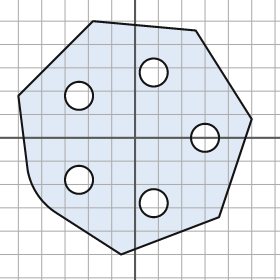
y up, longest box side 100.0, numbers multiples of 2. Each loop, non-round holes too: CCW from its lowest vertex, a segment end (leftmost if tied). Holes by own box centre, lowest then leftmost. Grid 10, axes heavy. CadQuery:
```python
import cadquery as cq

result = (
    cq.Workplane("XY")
    .moveTo(-6.0, -50.0)
    .lineTo(36.0, -34.0)
    .lineTo(50.0, 8.0)
    .lineTo(26.0, 46.0)
    .lineTo(-18.0, 50.0)
    .lineTo(-50.0, 18.0)
    .lineTo(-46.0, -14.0)
    .threePointArc((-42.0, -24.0), (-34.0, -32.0))
    .close()
    .moveTo(8.0, -28.0)
    .circle(6.0)
    .moveTo(-24.0, -18.0)
    .circle(6.0)
    .moveTo(30.0, 0.0)
    .circle(6.0)
    .moveTo(-24.0, 18.0)
    .circle(6.0)
    .moveTo(8.0, 28.0)
    .circle(6.0)
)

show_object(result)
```